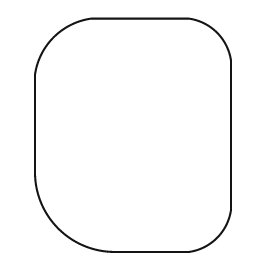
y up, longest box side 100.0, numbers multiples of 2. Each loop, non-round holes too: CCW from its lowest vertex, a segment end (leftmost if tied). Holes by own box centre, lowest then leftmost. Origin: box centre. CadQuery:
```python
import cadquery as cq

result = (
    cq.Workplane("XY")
    .moveTo(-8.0, -50.0)
    .lineTo(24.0, -50.0)
    .threePointArc((36.0, -44.0), (42.0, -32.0))
    .lineTo(42.0, 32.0)
    .threePointArc((36.0, 44.0), (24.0, 50.0))
    .lineTo(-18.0, 50.0)
    .threePointArc((-34.0, 42.0), (-42.0, 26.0))
    .lineTo(-42.0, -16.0)
    .threePointArc((-32.0, -40.0), (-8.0, -50.0))
    .close()
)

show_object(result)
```